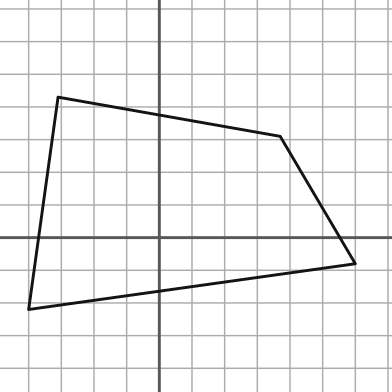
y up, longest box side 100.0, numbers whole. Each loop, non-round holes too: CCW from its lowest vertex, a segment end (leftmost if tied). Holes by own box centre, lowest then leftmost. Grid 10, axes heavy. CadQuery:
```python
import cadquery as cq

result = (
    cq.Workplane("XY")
    .moveTo(-40.0, -22.0)
    .lineTo(60.0, -8.0)
    .lineTo(37.0, 31.0)
    .lineTo(-31.0, 43.0)
    .close()
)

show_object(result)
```